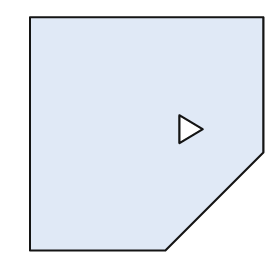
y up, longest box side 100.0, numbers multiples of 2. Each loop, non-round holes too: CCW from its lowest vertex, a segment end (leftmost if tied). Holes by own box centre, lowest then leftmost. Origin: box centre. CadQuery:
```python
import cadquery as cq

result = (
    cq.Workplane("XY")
    .moveTo(-50.0, -50.0)
    .lineTo(8.0, -50.0)
    .lineTo(50.0, -8.0)
    .lineTo(50.0, 50.0)
    .lineTo(-50.0, 50.0)
    .close()
    .moveTo(14.0, -4.0)
    .lineTo(24.0, 2.0)
    .lineTo(14.0, 8.0)
    .close()
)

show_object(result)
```